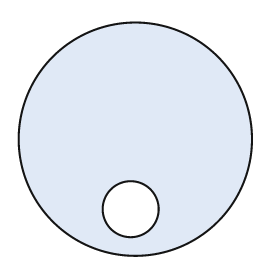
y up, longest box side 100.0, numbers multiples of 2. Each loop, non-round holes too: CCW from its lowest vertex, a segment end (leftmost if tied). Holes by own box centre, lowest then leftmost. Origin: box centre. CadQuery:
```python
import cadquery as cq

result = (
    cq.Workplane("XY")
    .moveTo(0.0, 0.0)
    .circle(50.0)
    .moveTo(-2.0, -30.0)
    .circle(12.0)
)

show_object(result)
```